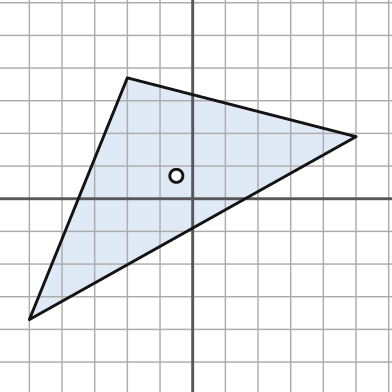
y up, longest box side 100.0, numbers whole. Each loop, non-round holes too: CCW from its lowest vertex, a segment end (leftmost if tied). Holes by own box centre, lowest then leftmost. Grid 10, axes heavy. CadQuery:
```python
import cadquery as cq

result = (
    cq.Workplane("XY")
    .moveTo(-50.0, -37.0)
    .lineTo(50.0, 19.0)
    .lineTo(-20.0, 37.0)
    .close()
    .moveTo(-5.0, 7.0)
    .circle(2.0)
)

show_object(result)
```